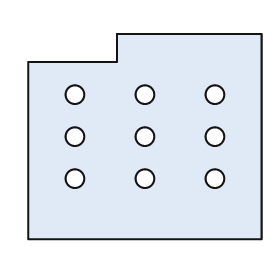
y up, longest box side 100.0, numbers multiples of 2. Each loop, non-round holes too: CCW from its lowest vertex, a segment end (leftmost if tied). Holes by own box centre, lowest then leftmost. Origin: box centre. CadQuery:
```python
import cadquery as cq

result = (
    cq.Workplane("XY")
    .moveTo(-50.0, -44.0)
    .lineTo(50.0, -44.0)
    .lineTo(50.0, 44.0)
    .lineTo(-12.0, 44.0)
    .lineTo(-12.0, 32.0)
    .lineTo(-50.0, 32.0)
    .close()
    .moveTo(-30.0, -18.0)
    .circle(4.0)
    .moveTo(0.0, -18.0)
    .circle(4.0)
    .moveTo(30.0, -18.0)
    .circle(4.0)
    .moveTo(-30.0, 0.0)
    .circle(4.0)
    .moveTo(0.0, 0.0)
    .circle(4.0)
    .moveTo(30.0, 0.0)
    .circle(4.0)
    .moveTo(-30.0, 18.0)
    .circle(4.0)
    .moveTo(0.0, 18.0)
    .circle(4.0)
    .moveTo(30.0, 18.0)
    .circle(4.0)
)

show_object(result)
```